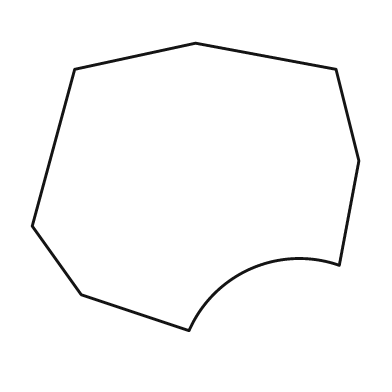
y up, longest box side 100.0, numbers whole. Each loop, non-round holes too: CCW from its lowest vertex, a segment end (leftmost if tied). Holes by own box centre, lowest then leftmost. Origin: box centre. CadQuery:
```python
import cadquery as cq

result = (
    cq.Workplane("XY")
    .moveTo(-2.0, -44.0)
    .threePointArc((17.0, -25.0), (44.0, -24.0))
    .lineTo(50.0, 8.0)
    .lineTo(43.0, 36.0)
    .lineTo(0.0, 44.0)
    .lineTo(-37.0, 36.0)
    .lineTo(-50.0, -12.0)
    .lineTo(-35.0, -33.0)
    .close()
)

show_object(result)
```